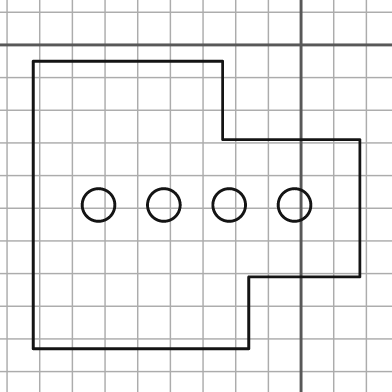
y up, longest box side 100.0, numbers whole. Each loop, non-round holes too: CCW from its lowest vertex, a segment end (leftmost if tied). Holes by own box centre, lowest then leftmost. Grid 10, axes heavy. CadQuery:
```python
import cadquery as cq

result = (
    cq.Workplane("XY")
    .moveTo(-82.0, -93.0)
    .lineTo(-16.0, -93.0)
    .lineTo(-16.0, -71.0)
    .lineTo(18.0, -71.0)
    .lineTo(18.0, -29.0)
    .lineTo(-24.0, -29.0)
    .lineTo(-24.0, -5.0)
    .lineTo(-82.0, -5.0)
    .close()
    .moveTo(-62.0, -49.0)
    .circle(5.0)
    .moveTo(-42.0, -49.0)
    .circle(5.0)
    .moveTo(-22.0, -49.0)
    .circle(5.0)
    .moveTo(-2.0, -49.0)
    .circle(5.0)
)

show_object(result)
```